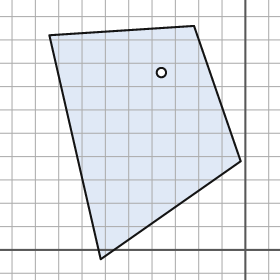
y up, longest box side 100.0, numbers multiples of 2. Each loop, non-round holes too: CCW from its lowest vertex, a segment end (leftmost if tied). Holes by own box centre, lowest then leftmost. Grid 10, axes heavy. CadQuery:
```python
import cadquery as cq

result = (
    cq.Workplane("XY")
    .moveTo(-62.0, -4.0)
    .lineTo(-2.0, 38.0)
    .lineTo(-22.0, 96.0)
    .lineTo(-84.0, 92.0)
    .close()
    .moveTo(-36.0, 76.0)
    .circle(2.0)
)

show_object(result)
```